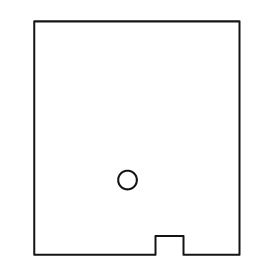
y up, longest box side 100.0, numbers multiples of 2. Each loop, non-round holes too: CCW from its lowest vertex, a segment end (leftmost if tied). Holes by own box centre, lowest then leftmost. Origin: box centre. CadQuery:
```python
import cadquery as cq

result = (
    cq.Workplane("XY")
    .moveTo(-44.0, -50.0)
    .lineTo(8.0, -50.0)
    .lineTo(8.0, -42.0)
    .lineTo(20.0, -42.0)
    .lineTo(20.0, -50.0)
    .lineTo(44.0, -50.0)
    .lineTo(44.0, 50.0)
    .lineTo(-44.0, 50.0)
    .close()
    .moveTo(-4.0, -18.0)
    .circle(4.0)
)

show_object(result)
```